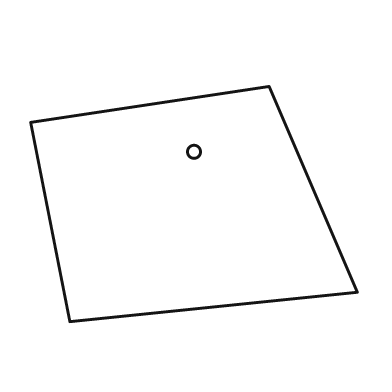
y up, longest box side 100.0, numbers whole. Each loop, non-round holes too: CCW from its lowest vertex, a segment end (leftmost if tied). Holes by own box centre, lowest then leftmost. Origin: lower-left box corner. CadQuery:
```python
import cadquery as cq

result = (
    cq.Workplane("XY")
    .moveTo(12.0, 0.0)
    .lineTo(100.0, 9.0)
    .lineTo(73.0, 72.0)
    .lineTo(0.0, 61.0)
    .close()
    .moveTo(50.0, 52.0)
    .circle(2.0)
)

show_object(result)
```